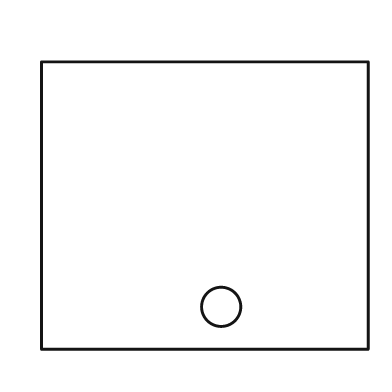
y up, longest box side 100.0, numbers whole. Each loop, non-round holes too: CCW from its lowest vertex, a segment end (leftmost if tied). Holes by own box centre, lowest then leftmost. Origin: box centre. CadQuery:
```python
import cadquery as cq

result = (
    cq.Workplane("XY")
    .moveTo(-50.0, -44.0)
    .lineTo(50.0, -44.0)
    .lineTo(50.0, 44.0)
    .lineTo(-50.0, 44.0)
    .close()
    .moveTo(5.0, -31.0)
    .circle(6.0)
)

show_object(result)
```